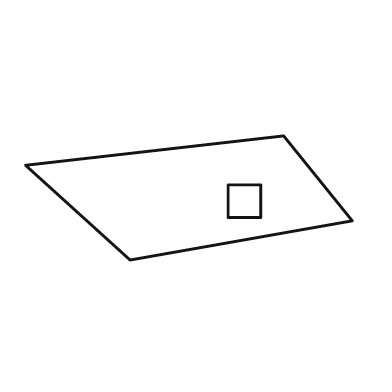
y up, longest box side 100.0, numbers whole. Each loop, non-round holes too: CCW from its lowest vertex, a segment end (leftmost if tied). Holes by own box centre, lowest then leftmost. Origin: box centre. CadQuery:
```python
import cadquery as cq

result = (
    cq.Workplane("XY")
    .moveTo(-18.0, -19.0)
    .lineTo(50.0, -7.0)
    .lineTo(29.0, 19.0)
    .lineTo(-50.0, 10.0)
    .close()
    .moveTo(12.0, -6.0)
    .lineTo(22.0, -6.0)
    .lineTo(22.0, 4.0)
    .lineTo(12.0, 4.0)
    .close()
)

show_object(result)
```